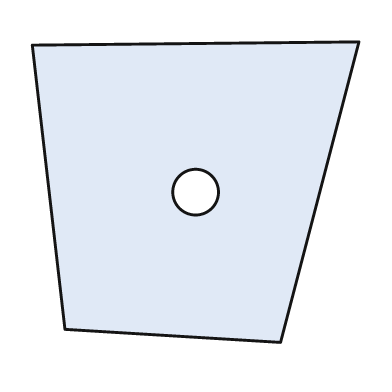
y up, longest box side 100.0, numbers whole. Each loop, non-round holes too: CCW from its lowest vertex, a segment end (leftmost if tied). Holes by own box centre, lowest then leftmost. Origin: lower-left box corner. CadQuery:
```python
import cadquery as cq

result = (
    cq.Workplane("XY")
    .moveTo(76.0, 0.0)
    .lineTo(100.0, 92.0)
    .lineTo(0.0, 91.0)
    .lineTo(10.0, 4.0)
    .close()
    .moveTo(50.0, 46.0)
    .circle(7.0)
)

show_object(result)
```